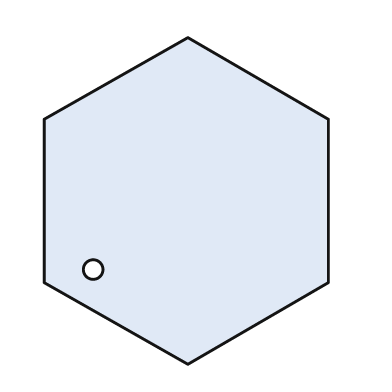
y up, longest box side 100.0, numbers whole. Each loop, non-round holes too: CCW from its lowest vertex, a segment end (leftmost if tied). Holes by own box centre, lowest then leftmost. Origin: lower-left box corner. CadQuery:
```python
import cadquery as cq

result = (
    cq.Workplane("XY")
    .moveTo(44.0, 0.0)
    .lineTo(87.0, 25.0)
    .lineTo(87.0, 75.0)
    .lineTo(44.0, 100.0)
    .lineTo(0.0, 75.0)
    .lineTo(0.0, 25.0)
    .close()
    .moveTo(15.0, 29.0)
    .circle(3.0)
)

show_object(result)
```